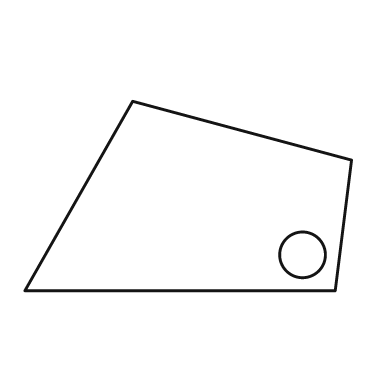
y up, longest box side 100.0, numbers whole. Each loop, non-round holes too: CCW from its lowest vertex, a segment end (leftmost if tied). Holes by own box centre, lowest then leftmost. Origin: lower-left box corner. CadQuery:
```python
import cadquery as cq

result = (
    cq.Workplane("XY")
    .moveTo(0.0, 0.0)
    .lineTo(95.0, 0.0)
    .lineTo(100.0, 40.0)
    .lineTo(33.0, 58.0)
    .close()
    .moveTo(85.0, 11.0)
    .circle(7.0)
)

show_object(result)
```